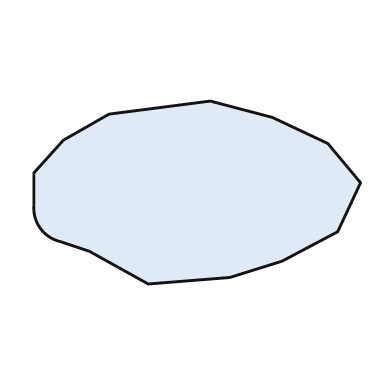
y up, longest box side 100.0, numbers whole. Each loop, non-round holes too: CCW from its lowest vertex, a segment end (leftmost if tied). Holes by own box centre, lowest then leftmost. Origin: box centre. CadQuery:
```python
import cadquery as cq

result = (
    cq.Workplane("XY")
    .moveTo(-15.0, -28.0)
    .lineTo(10.0, -26.0)
    .lineTo(26.0, -21.0)
    .lineTo(43.0, -12.0)
    .lineTo(50.0, 3.0)
    .lineTo(40.0, 15.0)
    .lineTo(23.0, 23.0)
    .lineTo(4.0, 28.0)
    .lineTo(-27.0, 24.0)
    .lineTo(-41.0, 16.0)
    .lineTo(-50.0, 6.0)
    .lineTo(-50.0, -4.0)
    .threePointArc((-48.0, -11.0), (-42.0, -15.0))
    .lineTo(-33.0, -18.0)
    .close()
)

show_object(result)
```